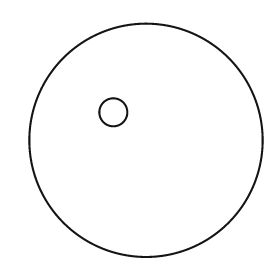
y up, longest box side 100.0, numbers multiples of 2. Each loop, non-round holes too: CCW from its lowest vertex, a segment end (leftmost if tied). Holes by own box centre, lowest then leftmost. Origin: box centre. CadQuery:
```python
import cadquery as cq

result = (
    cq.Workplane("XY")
    .moveTo(0.0, 0.0)
    .circle(50.0)
    .moveTo(-14.0, 12.0)
    .circle(6.0)
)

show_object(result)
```